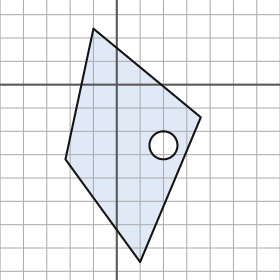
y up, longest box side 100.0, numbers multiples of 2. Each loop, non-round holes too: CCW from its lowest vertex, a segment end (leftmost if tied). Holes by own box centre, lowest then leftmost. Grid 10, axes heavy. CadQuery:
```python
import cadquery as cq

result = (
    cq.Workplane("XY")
    .moveTo(10.0, -76.0)
    .lineTo(36.0, -14.0)
    .lineTo(-10.0, 24.0)
    .lineTo(-22.0, -32.0)
    .close()
    .moveTo(20.0, -26.0)
    .circle(6.0)
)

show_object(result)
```